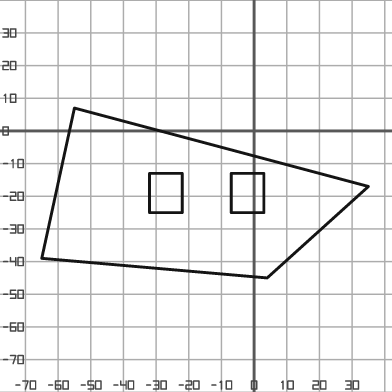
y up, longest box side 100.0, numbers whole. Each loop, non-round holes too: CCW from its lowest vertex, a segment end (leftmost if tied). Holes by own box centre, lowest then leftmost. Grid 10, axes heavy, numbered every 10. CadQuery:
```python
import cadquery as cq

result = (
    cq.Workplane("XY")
    .moveTo(4.0, -45.0)
    .lineTo(35.0, -17.0)
    .lineTo(-55.0, 7.0)
    .lineTo(-65.0, -39.0)
    .close()
    .moveTo(-32.0, -25.0)
    .lineTo(-22.0, -25.0)
    .lineTo(-22.0, -13.0)
    .lineTo(-32.0, -13.0)
    .close()
    .moveTo(-7.0, -25.0)
    .lineTo(3.0, -25.0)
    .lineTo(3.0, -13.0)
    .lineTo(-7.0, -13.0)
    .close()
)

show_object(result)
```